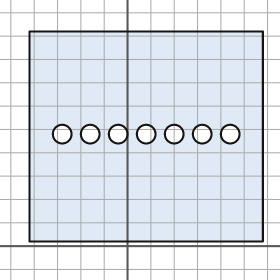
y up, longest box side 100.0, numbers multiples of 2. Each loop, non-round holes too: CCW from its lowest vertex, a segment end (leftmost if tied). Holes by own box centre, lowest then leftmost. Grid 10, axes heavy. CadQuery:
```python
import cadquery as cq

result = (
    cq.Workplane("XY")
    .moveTo(-42.0, 2.0)
    .lineTo(58.0, 2.0)
    .lineTo(58.0, 92.0)
    .lineTo(-42.0, 92.0)
    .close()
    .moveTo(-28.0, 48.0)
    .circle(4.0)
    .moveTo(-16.0, 48.0)
    .circle(4.0)
    .moveTo(-4.0, 48.0)
    .circle(4.0)
    .moveTo(8.0, 48.0)
    .circle(4.0)
    .moveTo(20.0, 48.0)
    .circle(4.0)
    .moveTo(32.0, 48.0)
    .circle(4.0)
    .moveTo(44.0, 48.0)
    .circle(4.0)
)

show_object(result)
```